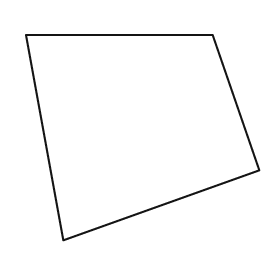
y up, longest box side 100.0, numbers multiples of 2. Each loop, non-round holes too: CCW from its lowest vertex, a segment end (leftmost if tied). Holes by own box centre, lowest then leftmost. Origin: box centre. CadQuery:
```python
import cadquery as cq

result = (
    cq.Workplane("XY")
    .moveTo(-34.0, -44.0)
    .lineTo(50.0, -14.0)
    .lineTo(30.0, 44.0)
    .lineTo(-50.0, 44.0)
    .close()
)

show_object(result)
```